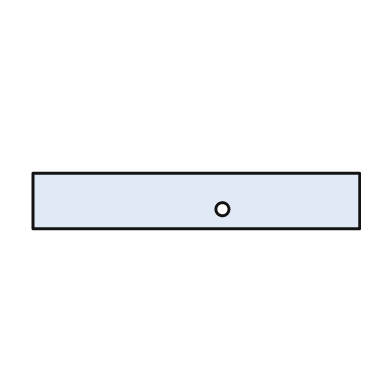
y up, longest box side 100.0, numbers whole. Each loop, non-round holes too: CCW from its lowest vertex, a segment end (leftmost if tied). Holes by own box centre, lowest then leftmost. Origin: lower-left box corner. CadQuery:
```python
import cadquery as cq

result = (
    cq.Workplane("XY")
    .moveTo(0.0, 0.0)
    .lineTo(100.0, 0.0)
    .lineTo(100.0, 17.0)
    .lineTo(0.0, 17.0)
    .close()
    .moveTo(58.0, 6.0)
    .circle(2.0)
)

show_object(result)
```